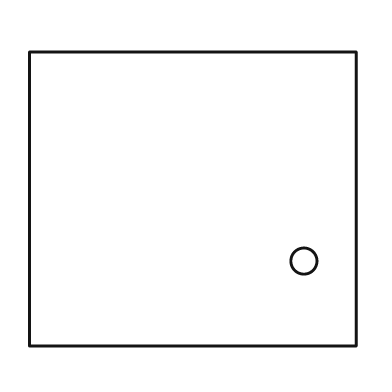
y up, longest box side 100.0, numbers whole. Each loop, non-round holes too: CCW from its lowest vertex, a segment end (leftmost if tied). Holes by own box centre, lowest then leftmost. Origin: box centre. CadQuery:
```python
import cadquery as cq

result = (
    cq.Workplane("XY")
    .moveTo(-50.0, -45.0)
    .lineTo(50.0, -45.0)
    .lineTo(50.0, 45.0)
    .lineTo(-50.0, 45.0)
    .close()
    .moveTo(34.0, -19.0)
    .circle(4.0)
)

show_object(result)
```